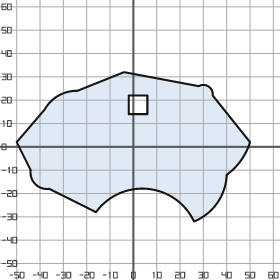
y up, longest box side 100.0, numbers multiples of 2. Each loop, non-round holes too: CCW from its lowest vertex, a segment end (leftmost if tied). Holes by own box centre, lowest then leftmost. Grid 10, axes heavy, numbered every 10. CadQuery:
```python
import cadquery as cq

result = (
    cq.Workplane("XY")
    .moveTo(26.0, -32.0)
    .threePointArc((36.0, -24.0), (40.0, -12.0))
    .threePointArc((46.0, -6.0), (50.0, 2.0))
    .lineTo(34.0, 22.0)
    .threePointArc((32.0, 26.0), (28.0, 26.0))
    .lineTo(-4.0, 32.0)
    .lineTo(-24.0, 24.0)
    .threePointArc((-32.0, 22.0), (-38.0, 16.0))
    .lineTo(-50.0, 2.0)
    .lineTo(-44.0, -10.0)
    .threePointArc((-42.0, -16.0), (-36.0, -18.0))
    .lineTo(-16.0, -28.0)
    .threePointArc((6.0, -18.0), (26.0, -32.0))
    .close()
    .moveTo(-2.0, 14.0)
    .lineTo(6.0, 14.0)
    .lineTo(6.0, 22.0)
    .lineTo(-2.0, 22.0)
    .close()
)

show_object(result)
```